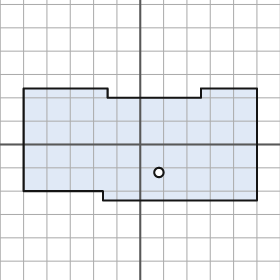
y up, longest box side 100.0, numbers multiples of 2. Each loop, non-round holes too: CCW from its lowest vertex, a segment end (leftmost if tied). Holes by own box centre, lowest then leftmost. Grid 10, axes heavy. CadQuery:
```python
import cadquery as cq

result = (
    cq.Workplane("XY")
    .moveTo(-16.0, -24.0)
    .lineTo(50.0, -24.0)
    .lineTo(50.0, 24.0)
    .lineTo(26.0, 24.0)
    .lineTo(26.0, 20.0)
    .lineTo(-14.0, 20.0)
    .lineTo(-14.0, 24.0)
    .lineTo(-50.0, 24.0)
    .lineTo(-50.0, -20.0)
    .lineTo(-16.0, -20.0)
    .close()
    .moveTo(8.0, -12.0)
    .circle(2.0)
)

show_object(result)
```